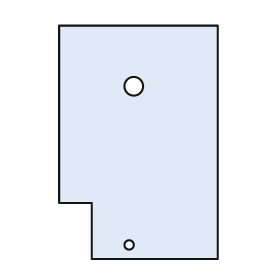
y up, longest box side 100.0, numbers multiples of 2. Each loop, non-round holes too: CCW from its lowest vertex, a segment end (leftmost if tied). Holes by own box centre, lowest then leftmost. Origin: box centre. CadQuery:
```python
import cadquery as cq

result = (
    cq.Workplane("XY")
    .moveTo(-20.0, -50.0)
    .lineTo(34.0, -50.0)
    .lineTo(34.0, 50.0)
    .lineTo(-34.0, 50.0)
    .lineTo(-34.0, -26.0)
    .lineTo(-20.0, -26.0)
    .close()
    .moveTo(-4.0, -44.0)
    .circle(2.0)
    .moveTo(-2.0, 24.0)
    .circle(4.0)
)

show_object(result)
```